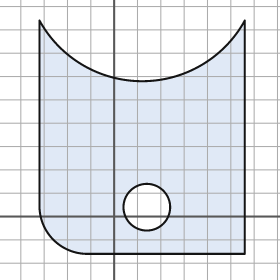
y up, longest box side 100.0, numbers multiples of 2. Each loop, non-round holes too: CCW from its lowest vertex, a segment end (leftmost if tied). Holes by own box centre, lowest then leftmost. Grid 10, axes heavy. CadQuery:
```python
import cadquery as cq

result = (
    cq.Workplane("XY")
    .moveTo(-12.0, -16.0)
    .lineTo(56.0, -16.0)
    .lineTo(56.0, 84.0)
    .threePointArc((12.0, 58.0), (-32.0, 84.0))
    .lineTo(-32.0, 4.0)
    .threePointArc((-26.0, -10.0), (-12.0, -16.0))
    .close()
    .moveTo(14.0, 4.0)
    .circle(10.0)
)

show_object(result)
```